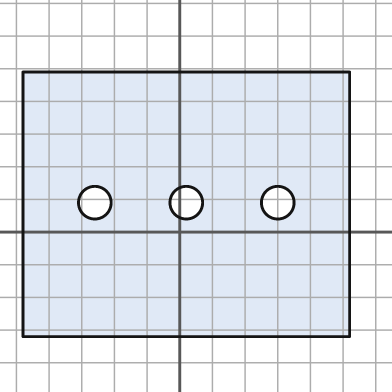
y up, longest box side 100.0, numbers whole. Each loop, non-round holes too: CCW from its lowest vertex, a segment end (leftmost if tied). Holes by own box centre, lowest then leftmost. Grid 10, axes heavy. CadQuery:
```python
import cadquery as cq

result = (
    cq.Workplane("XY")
    .moveTo(-48.0, -32.0)
    .lineTo(52.0, -32.0)
    .lineTo(52.0, 49.0)
    .lineTo(-48.0, 49.0)
    .close()
    .moveTo(-26.0, 9.0)
    .circle(5.0)
    .moveTo(2.0, 9.0)
    .circle(5.0)
    .moveTo(30.0, 9.0)
    .circle(5.0)
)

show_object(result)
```